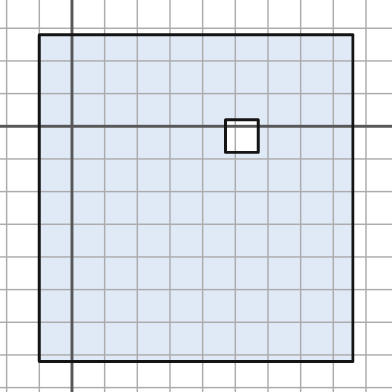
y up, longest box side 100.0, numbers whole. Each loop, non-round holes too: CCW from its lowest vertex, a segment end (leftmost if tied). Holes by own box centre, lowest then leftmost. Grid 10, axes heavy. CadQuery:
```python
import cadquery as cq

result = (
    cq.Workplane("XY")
    .moveTo(-10.0, -72.0)
    .lineTo(86.0, -72.0)
    .lineTo(86.0, 28.0)
    .lineTo(-10.0, 28.0)
    .close()
    .moveTo(47.0, -8.0)
    .lineTo(57.0, -8.0)
    .lineTo(57.0, 2.0)
    .lineTo(47.0, 2.0)
    .close()
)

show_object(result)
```